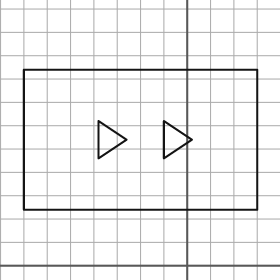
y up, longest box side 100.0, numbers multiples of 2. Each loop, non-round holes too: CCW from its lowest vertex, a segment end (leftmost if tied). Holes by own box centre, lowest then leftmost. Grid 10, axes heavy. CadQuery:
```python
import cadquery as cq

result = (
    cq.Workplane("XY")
    .moveTo(-70.0, 24.0)
    .lineTo(30.0, 24.0)
    .lineTo(30.0, 84.0)
    .lineTo(-70.0, 84.0)
    .close()
    .moveTo(-38.0, 46.0)
    .lineTo(-26.0, 54.0)
    .lineTo(-38.0, 62.0)
    .close()
    .moveTo(-10.0, 46.0)
    .lineTo(2.0, 54.0)
    .lineTo(-10.0, 62.0)
    .close()
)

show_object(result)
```